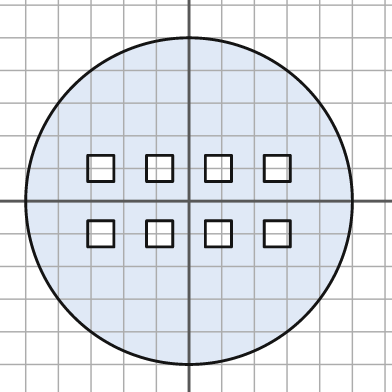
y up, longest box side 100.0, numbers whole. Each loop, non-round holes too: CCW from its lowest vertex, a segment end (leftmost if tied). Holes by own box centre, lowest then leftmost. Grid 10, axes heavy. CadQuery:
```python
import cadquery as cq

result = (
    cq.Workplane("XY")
    .moveTo(0.0, 0.0)
    .circle(50.0)
    .moveTo(-31.0, -14.0)
    .lineTo(-23.0, -14.0)
    .lineTo(-23.0, -6.0)
    .lineTo(-31.0, -6.0)
    .close()
    .moveTo(-13.0, -14.0)
    .lineTo(-5.0, -14.0)
    .lineTo(-5.0, -6.0)
    .lineTo(-13.0, -6.0)
    .close()
    .moveTo(5.0, -14.0)
    .lineTo(13.0, -14.0)
    .lineTo(13.0, -6.0)
    .lineTo(5.0, -6.0)
    .close()
    .moveTo(23.0, -14.0)
    .lineTo(31.0, -14.0)
    .lineTo(31.0, -6.0)
    .lineTo(23.0, -6.0)
    .close()
    .moveTo(-31.0, 6.0)
    .lineTo(-23.0, 6.0)
    .lineTo(-23.0, 14.0)
    .lineTo(-31.0, 14.0)
    .close()
    .moveTo(-13.0, 6.0)
    .lineTo(-5.0, 6.0)
    .lineTo(-5.0, 14.0)
    .lineTo(-13.0, 14.0)
    .close()
    .moveTo(5.0, 6.0)
    .lineTo(13.0, 6.0)
    .lineTo(13.0, 14.0)
    .lineTo(5.0, 14.0)
    .close()
    .moveTo(23.0, 6.0)
    .lineTo(31.0, 6.0)
    .lineTo(31.0, 14.0)
    .lineTo(23.0, 14.0)
    .close()
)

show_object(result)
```